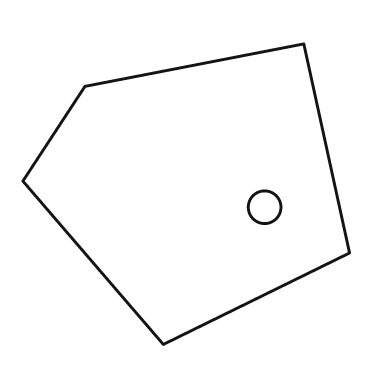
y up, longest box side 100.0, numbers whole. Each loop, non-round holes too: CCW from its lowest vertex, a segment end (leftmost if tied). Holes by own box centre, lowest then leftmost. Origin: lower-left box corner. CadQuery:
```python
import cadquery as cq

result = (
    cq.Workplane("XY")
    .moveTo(43.0, 0.0)
    .lineTo(100.0, 28.0)
    .lineTo(86.0, 92.0)
    .lineTo(19.0, 79.0)
    .lineTo(0.0, 50.0)
    .close()
    .moveTo(74.0, 42.0)
    .circle(5.0)
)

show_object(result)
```